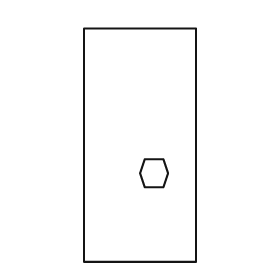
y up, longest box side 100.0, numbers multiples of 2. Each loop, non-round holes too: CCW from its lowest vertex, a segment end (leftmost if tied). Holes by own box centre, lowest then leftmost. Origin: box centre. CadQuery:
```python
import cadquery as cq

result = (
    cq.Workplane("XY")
    .moveTo(-24.0, -50.0)
    .lineTo(24.0, -50.0)
    .lineTo(24.0, 50.0)
    .lineTo(-24.0, 50.0)
    .close()
    .moveTo(2.0, -18.0)
    .lineTo(10.0, -18.0)
    .lineTo(12.0, -12.0)
    .lineTo(10.0, -6.0)
    .lineTo(2.0, -6.0)
    .lineTo(0.0, -12.0)
    .close()
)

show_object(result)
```